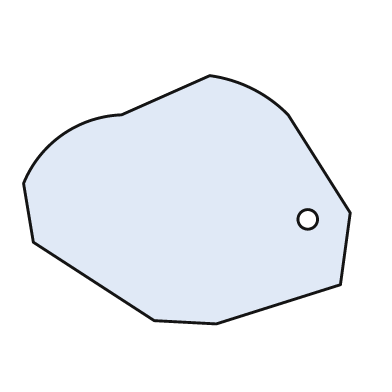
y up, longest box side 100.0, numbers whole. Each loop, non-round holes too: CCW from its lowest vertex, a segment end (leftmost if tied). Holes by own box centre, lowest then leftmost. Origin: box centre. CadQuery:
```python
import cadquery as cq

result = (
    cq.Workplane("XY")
    .moveTo(9.0, -38.0)
    .lineTo(47.0, -26.0)
    .lineTo(50.0, -4.0)
    .lineTo(31.0, 26.0)
    .threePointArc((20.0, 34.0), (7.0, 38.0))
    .lineTo(-20.0, 26.0)
    .threePointArc((-38.0, 20.0), (-50.0, 5.0))
    .lineTo(-47.0, -13.0)
    .lineTo(-10.0, -37.0)
    .close()
    .moveTo(37.0, -6.0)
    .circle(3.0)
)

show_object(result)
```